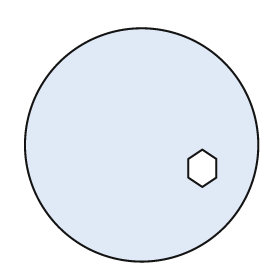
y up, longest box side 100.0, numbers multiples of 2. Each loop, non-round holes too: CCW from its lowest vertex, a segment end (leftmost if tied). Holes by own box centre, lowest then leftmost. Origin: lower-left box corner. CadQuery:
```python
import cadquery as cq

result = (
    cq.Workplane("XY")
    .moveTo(50.0, 50.0)
    .circle(50.0)
    .moveTo(76.0, 32.0)
    .lineTo(82.0, 36.0)
    .lineTo(82.0, 44.0)
    .lineTo(76.0, 48.0)
    .lineTo(70.0, 44.0)
    .lineTo(70.0, 36.0)
    .close()
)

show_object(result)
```